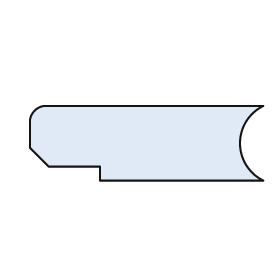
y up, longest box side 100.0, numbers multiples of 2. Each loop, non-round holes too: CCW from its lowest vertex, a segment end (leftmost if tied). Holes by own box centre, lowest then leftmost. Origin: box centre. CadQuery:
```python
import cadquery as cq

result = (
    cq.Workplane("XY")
    .moveTo(-20.0, -16.0)
    .lineTo(50.0, -16.0)
    .threePointArc((40.0, 0.0), (50.0, 16.0))
    .lineTo(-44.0, 16.0)
    .threePointArc((-48.0, 14.0), (-50.0, 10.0))
    .lineTo(-50.0, -2.0)
    .lineTo(-42.0, -10.0)
    .lineTo(-20.0, -10.0)
    .close()
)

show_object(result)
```